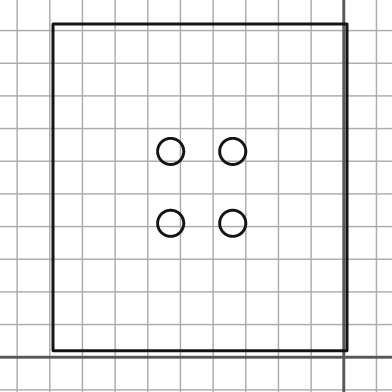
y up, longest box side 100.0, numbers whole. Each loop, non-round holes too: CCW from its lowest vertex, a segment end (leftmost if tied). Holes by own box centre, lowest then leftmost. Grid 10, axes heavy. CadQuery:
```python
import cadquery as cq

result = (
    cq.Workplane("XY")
    .moveTo(-89.0, 2.0)
    .lineTo(1.0, 2.0)
    .lineTo(1.0, 102.0)
    .lineTo(-89.0, 102.0)
    .close()
    .moveTo(-53.0, 41.0)
    .circle(4.0)
    .moveTo(-34.0, 41.0)
    .circle(4.0)
    .moveTo(-53.0, 63.0)
    .circle(4.0)
    .moveTo(-34.0, 63.0)
    .circle(4.0)
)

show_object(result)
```